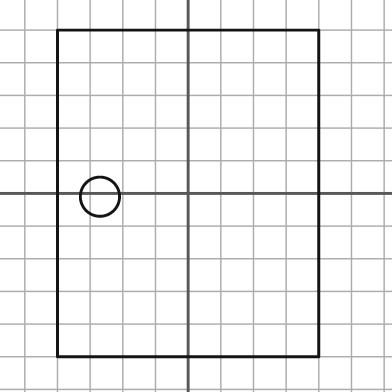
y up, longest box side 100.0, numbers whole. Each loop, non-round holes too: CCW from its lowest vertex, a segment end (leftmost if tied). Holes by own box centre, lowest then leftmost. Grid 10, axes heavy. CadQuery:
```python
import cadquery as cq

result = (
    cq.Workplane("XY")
    .moveTo(-40.0, -50.0)
    .lineTo(40.0, -50.0)
    .lineTo(40.0, 50.0)
    .lineTo(-40.0, 50.0)
    .close()
    .moveTo(-27.0, -1.0)
    .circle(6.0)
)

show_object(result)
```